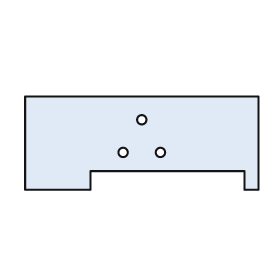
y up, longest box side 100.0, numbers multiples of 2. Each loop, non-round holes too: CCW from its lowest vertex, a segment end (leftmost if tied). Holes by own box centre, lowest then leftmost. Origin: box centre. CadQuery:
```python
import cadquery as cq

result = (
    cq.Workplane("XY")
    .moveTo(-50.0, -20.0)
    .lineTo(-22.0, -20.0)
    .lineTo(-22.0, -12.0)
    .lineTo(44.0, -12.0)
    .lineTo(44.0, -20.0)
    .lineTo(50.0, -20.0)
    .lineTo(50.0, 20.0)
    .lineTo(-50.0, 20.0)
    .close()
    .moveTo(-8.0, -4.0)
    .circle(2.0)
    .moveTo(8.0, -4.0)
    .circle(2.0)
    .moveTo(0.0, 10.0)
    .circle(2.0)
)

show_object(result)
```